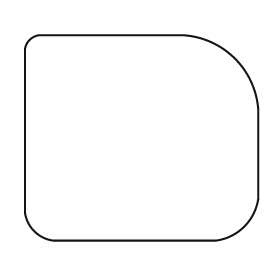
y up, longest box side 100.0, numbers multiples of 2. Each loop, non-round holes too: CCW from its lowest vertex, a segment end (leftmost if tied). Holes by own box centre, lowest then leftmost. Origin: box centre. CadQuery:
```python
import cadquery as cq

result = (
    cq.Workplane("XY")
    .moveTo(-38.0, -44.0)
    .lineTo(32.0, -44.0)
    .threePointArc((44.0, -38.0), (50.0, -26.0))
    .lineTo(50.0, 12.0)
    .threePointArc((40.0, 34.0), (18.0, 44.0))
    .lineTo(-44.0, 44.0)
    .threePointArc((-48.0, 42.0), (-50.0, 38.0))
    .lineTo(-50.0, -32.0)
    .threePointArc((-46.0, -40.0), (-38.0, -44.0))
    .close()
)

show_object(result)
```